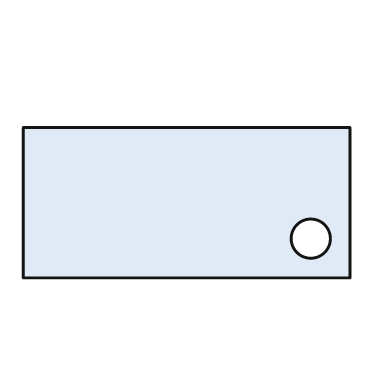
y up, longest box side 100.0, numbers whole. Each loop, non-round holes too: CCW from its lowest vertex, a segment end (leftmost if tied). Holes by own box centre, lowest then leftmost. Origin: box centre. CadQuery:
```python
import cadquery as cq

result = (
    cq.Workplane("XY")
    .moveTo(-50.0, -23.0)
    .lineTo(50.0, -23.0)
    .lineTo(50.0, 23.0)
    .lineTo(-50.0, 23.0)
    .close()
    .moveTo(38.0, -11.0)
    .circle(6.0)
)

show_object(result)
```